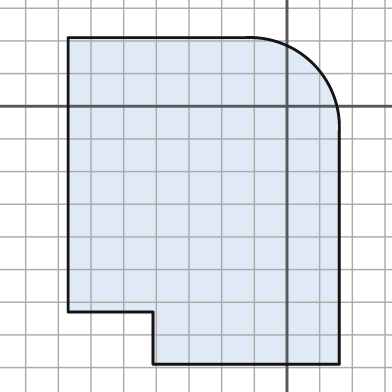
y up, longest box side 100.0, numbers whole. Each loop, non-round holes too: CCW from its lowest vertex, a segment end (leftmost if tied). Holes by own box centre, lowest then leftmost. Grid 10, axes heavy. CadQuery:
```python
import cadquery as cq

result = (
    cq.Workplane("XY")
    .moveTo(-41.0, -79.0)
    .lineTo(16.0, -79.0)
    .lineTo(16.0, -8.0)
    .threePointArc((8.0, 13.0), (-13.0, 21.0))
    .lineTo(-67.0, 21.0)
    .lineTo(-67.0, -63.0)
    .lineTo(-41.0, -63.0)
    .close()
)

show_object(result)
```